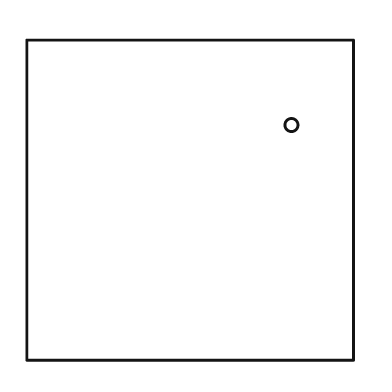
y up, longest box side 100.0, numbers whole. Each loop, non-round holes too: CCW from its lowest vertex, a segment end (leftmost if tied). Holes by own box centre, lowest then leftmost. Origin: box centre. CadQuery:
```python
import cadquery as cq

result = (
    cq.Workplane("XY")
    .moveTo(-50.0, -49.0)
    .lineTo(50.0, -49.0)
    .lineTo(50.0, 49.0)
    .lineTo(-50.0, 49.0)
    .close()
    .moveTo(31.0, 23.0)
    .circle(2.0)
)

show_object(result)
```